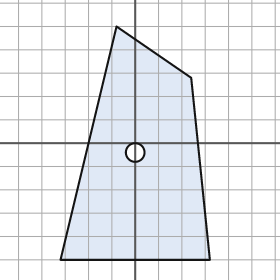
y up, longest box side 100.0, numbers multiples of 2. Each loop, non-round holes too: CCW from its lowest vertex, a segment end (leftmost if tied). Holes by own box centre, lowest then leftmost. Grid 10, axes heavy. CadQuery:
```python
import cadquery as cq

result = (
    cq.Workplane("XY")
    .moveTo(-32.0, -50.0)
    .lineTo(32.0, -50.0)
    .lineTo(24.0, 28.0)
    .lineTo(-8.0, 50.0)
    .close()
    .moveTo(0.0, -4.0)
    .circle(4.0)
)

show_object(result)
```